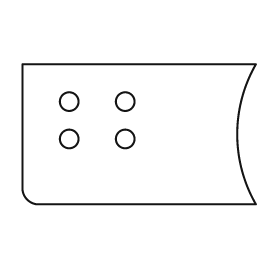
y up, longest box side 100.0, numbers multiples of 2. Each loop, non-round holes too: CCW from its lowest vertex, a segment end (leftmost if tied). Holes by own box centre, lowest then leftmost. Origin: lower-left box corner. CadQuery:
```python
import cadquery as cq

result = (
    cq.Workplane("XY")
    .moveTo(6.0, 0.0)
    .lineTo(100.0, 0.0)
    .threePointArc((92.0, 30.0), (100.0, 60.0))
    .lineTo(0.0, 60.0)
    .lineTo(0.0, 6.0)
    .threePointArc((2.0, 2.0), (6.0, 0.0))
    .close()
    .moveTo(20.0, 28.0)
    .circle(4.0)
    .moveTo(44.0, 28.0)
    .circle(4.0)
    .moveTo(20.0, 44.0)
    .circle(4.0)
    .moveTo(44.0, 44.0)
    .circle(4.0)
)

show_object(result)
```